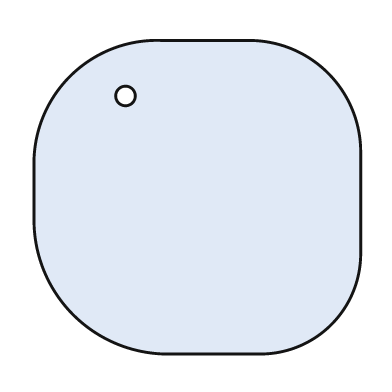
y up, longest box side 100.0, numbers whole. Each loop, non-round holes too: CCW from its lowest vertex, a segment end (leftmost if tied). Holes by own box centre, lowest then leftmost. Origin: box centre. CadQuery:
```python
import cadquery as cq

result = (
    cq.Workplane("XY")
    .moveTo(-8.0, -48.0)
    .lineTo(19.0, -48.0)
    .threePointArc((41.0, -39.0), (50.0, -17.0))
    .lineTo(50.0, 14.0)
    .threePointArc((40.0, 38.0), (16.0, 48.0))
    .lineTo(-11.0, 48.0)
    .threePointArc((-39.0, 37.0), (-50.0, 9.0))
    .lineTo(-50.0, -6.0)
    .threePointArc((-38.0, -36.0), (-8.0, -48.0))
    .close()
    .moveTo(-22.0, 31.0)
    .circle(3.0)
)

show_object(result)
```